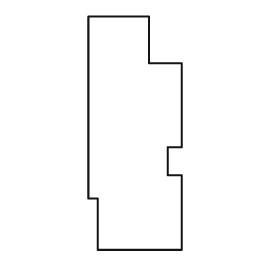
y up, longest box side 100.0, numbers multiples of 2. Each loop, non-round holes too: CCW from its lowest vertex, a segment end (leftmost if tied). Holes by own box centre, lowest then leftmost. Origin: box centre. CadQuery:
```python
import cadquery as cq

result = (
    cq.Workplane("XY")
    .moveTo(-16.0, -50.0)
    .lineTo(20.0, -50.0)
    .lineTo(20.0, -18.0)
    .lineTo(14.0, -18.0)
    .lineTo(14.0, -6.0)
    .lineTo(20.0, -6.0)
    .lineTo(20.0, 30.0)
    .lineTo(6.0, 30.0)
    .lineTo(6.0, 50.0)
    .lineTo(-20.0, 50.0)
    .lineTo(-20.0, -28.0)
    .lineTo(-16.0, -28.0)
    .close()
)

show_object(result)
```